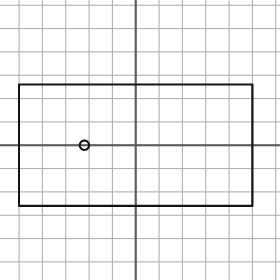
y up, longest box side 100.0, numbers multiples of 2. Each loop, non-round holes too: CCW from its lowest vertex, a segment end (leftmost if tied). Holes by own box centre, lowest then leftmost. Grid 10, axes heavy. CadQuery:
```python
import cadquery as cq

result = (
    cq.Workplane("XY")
    .moveTo(-50.0, -26.0)
    .lineTo(50.0, -26.0)
    .lineTo(50.0, 26.0)
    .lineTo(-50.0, 26.0)
    .close()
    .moveTo(-22.0, 0.0)
    .circle(2.0)
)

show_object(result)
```